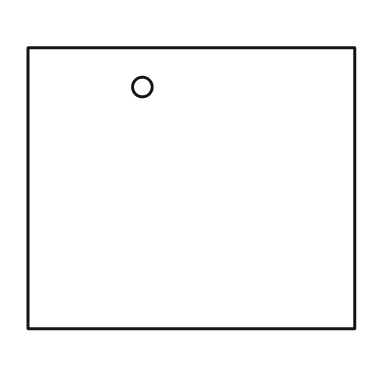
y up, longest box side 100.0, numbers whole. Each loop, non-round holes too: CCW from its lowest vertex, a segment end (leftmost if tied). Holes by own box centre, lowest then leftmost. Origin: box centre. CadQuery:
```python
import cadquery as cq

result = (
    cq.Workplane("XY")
    .moveTo(-50.0, -43.0)
    .lineTo(50.0, -43.0)
    .lineTo(50.0, 43.0)
    .lineTo(-50.0, 43.0)
    .close()
    .moveTo(-15.0, 31.0)
    .circle(3.0)
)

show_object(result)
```